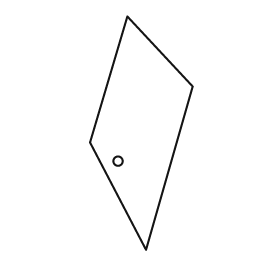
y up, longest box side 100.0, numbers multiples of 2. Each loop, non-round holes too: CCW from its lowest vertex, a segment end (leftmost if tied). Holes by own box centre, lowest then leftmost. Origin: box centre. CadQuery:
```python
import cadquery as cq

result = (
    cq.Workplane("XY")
    .moveTo(2.0, -50.0)
    .lineTo(22.0, 20.0)
    .lineTo(-6.0, 50.0)
    .lineTo(-22.0, -4.0)
    .close()
    .moveTo(-10.0, -12.0)
    .circle(2.0)
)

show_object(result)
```